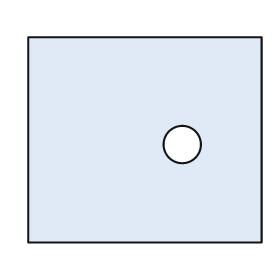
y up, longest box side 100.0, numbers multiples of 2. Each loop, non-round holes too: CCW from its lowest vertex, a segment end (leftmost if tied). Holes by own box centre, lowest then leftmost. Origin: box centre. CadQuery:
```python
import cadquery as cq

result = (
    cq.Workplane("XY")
    .moveTo(-50.0, -44.0)
    .lineTo(50.0, -44.0)
    .lineTo(50.0, 44.0)
    .lineTo(-50.0, 44.0)
    .close()
    .moveTo(16.0, -2.0)
    .circle(8.0)
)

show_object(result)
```